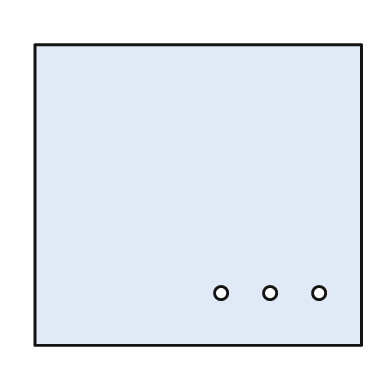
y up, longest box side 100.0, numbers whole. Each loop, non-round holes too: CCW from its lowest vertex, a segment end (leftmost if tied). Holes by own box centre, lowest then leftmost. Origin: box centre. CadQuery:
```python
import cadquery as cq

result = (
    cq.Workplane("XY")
    .moveTo(-50.0, -46.0)
    .lineTo(50.0, -46.0)
    .lineTo(50.0, 46.0)
    .lineTo(-50.0, 46.0)
    .close()
    .moveTo(7.0, -30.0)
    .circle(2.0)
    .moveTo(22.0, -30.0)
    .circle(2.0)
    .moveTo(37.0, -30.0)
    .circle(2.0)
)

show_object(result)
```